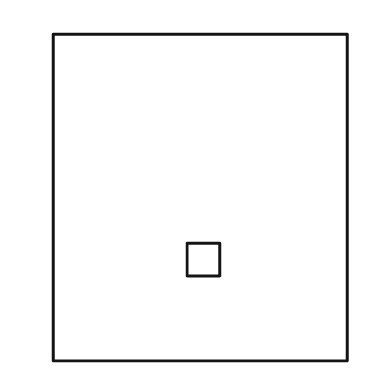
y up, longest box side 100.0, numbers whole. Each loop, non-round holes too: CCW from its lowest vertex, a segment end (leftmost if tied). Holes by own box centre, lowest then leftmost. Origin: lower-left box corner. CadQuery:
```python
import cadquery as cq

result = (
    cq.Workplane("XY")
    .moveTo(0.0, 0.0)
    .lineTo(90.0, 0.0)
    .lineTo(90.0, 100.0)
    .lineTo(0.0, 100.0)
    .close()
    .moveTo(41.0, 26.0)
    .lineTo(51.0, 26.0)
    .lineTo(51.0, 36.0)
    .lineTo(41.0, 36.0)
    .close()
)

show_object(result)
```